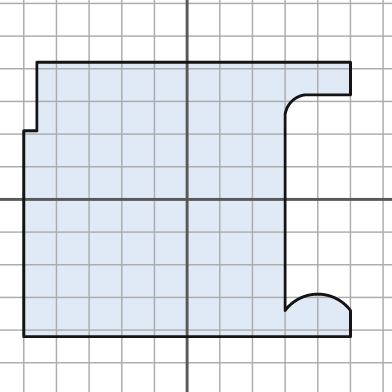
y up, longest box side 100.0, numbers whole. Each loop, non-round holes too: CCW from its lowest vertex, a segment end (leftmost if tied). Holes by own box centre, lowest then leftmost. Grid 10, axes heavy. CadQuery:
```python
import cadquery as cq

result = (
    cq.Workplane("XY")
    .moveTo(-50.0, -42.0)
    .lineTo(50.0, -42.0)
    .lineTo(50.0, -34.0)
    .threePointArc((40.0, -29.0), (30.0, -34.0))
    .lineTo(30.0, 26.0)
    .threePointArc((32.0, 30.0), (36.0, 32.0))
    .lineTo(50.0, 32.0)
    .lineTo(50.0, 42.0)
    .lineTo(-46.0, 42.0)
    .lineTo(-46.0, 21.0)
    .lineTo(-50.0, 21.0)
    .close()
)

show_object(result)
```